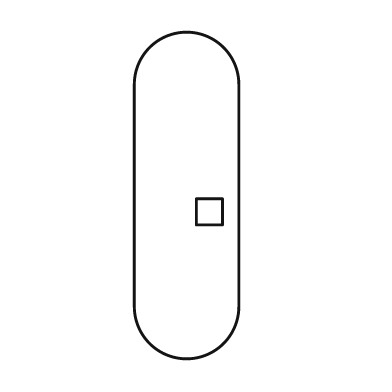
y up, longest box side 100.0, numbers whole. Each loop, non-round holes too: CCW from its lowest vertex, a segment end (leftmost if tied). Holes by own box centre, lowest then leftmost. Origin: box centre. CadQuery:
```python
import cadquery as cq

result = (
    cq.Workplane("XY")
    .moveTo(-16.0, -34.0)
    .threePointArc((0.0, -50.0), (16.0, -34.0))
    .lineTo(16.0, 34.0)
    .threePointArc((0.0, 50.0), (-16.0, 34.0))
    .close()
    .moveTo(3.0, -9.0)
    .lineTo(11.0, -9.0)
    .lineTo(11.0, -1.0)
    .lineTo(3.0, -1.0)
    .close()
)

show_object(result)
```